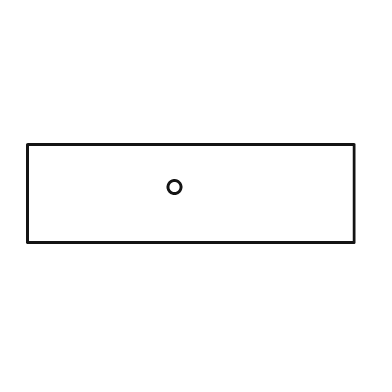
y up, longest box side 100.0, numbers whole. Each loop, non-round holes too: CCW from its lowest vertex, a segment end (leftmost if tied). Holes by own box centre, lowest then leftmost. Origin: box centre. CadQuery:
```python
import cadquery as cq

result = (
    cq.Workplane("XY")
    .moveTo(-50.0, -15.0)
    .lineTo(50.0, -15.0)
    .lineTo(50.0, 15.0)
    .lineTo(-50.0, 15.0)
    .close()
    .moveTo(-5.0, 2.0)
    .circle(2.0)
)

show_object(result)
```